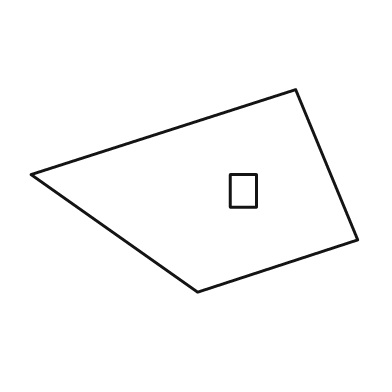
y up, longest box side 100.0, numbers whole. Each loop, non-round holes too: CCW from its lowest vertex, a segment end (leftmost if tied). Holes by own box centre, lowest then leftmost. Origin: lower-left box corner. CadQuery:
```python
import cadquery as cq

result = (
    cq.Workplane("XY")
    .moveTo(51.0, 0.0)
    .lineTo(100.0, 16.0)
    .lineTo(81.0, 62.0)
    .lineTo(0.0, 36.0)
    .close()
    .moveTo(61.0, 26.0)
    .lineTo(69.0, 26.0)
    .lineTo(69.0, 36.0)
    .lineTo(61.0, 36.0)
    .close()
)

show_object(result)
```